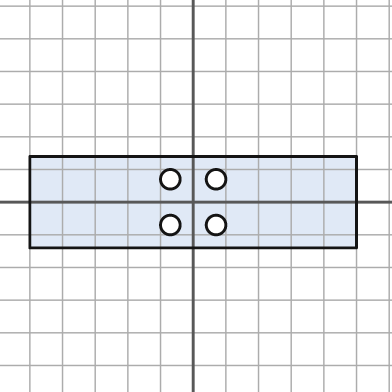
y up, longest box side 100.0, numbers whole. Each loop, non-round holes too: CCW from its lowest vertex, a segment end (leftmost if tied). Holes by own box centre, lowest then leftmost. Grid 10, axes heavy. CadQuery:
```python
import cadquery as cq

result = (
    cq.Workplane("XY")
    .moveTo(-50.0, -14.0)
    .lineTo(50.0, -14.0)
    .lineTo(50.0, 14.0)
    .lineTo(-50.0, 14.0)
    .close()
    .moveTo(-7.0, -7.0)
    .circle(3.0)
    .moveTo(7.0, -7.0)
    .circle(3.0)
    .moveTo(-7.0, 7.0)
    .circle(3.0)
    .moveTo(7.0, 7.0)
    .circle(3.0)
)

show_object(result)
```